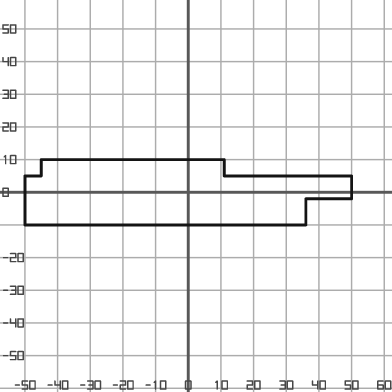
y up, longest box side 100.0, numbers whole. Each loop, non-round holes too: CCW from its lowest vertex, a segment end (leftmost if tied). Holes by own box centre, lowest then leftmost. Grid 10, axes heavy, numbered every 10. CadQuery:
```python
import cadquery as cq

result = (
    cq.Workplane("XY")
    .moveTo(-50.0, -10.0)
    .lineTo(36.0, -10.0)
    .lineTo(36.0, -2.0)
    .lineTo(50.0, -2.0)
    .lineTo(50.0, 5.0)
    .lineTo(11.0, 5.0)
    .lineTo(11.0, 10.0)
    .lineTo(-45.0, 10.0)
    .lineTo(-45.0, 5.0)
    .lineTo(-50.0, 5.0)
    .close()
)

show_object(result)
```